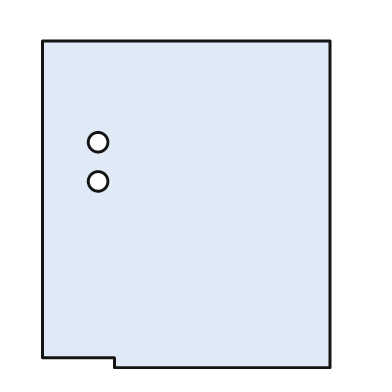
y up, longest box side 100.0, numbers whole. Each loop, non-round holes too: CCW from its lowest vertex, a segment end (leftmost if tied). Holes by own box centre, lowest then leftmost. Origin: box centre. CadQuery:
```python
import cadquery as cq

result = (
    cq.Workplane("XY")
    .moveTo(-22.0, -50.0)
    .lineTo(44.0, -50.0)
    .lineTo(44.0, 50.0)
    .lineTo(-44.0, 50.0)
    .lineTo(-44.0, -47.0)
    .lineTo(-22.0, -47.0)
    .close()
    .moveTo(-27.0, 7.0)
    .circle(3.0)
    .moveTo(-27.0, 19.0)
    .circle(3.0)
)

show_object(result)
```